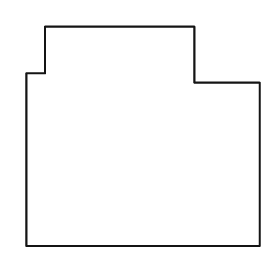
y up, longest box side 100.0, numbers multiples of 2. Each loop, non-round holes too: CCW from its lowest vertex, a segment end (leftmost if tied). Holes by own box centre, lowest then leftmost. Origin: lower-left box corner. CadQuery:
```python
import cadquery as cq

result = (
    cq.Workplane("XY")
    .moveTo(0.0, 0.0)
    .lineTo(100.0, 0.0)
    .lineTo(100.0, 70.0)
    .lineTo(72.0, 70.0)
    .lineTo(72.0, 94.0)
    .lineTo(8.0, 94.0)
    .lineTo(8.0, 74.0)
    .lineTo(0.0, 74.0)
    .close()
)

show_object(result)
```